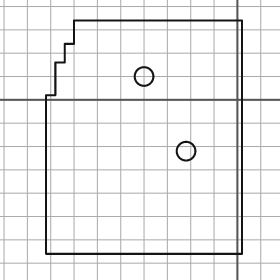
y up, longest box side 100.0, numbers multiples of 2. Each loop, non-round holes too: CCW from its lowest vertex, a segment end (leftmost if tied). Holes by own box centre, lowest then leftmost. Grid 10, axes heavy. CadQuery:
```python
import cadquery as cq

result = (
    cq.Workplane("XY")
    .moveTo(-82.0, -66.0)
    .lineTo(2.0, -66.0)
    .lineTo(2.0, 34.0)
    .lineTo(-70.0, 34.0)
    .lineTo(-70.0, 24.0)
    .lineTo(-74.0, 24.0)
    .lineTo(-74.0, 16.0)
    .lineTo(-78.0, 16.0)
    .lineTo(-78.0, 2.0)
    .lineTo(-82.0, 2.0)
    .close()
    .moveTo(-22.0, -22.0)
    .circle(4.0)
    .moveTo(-40.0, 10.0)
    .circle(4.0)
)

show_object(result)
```